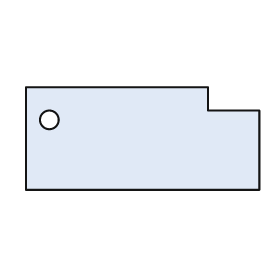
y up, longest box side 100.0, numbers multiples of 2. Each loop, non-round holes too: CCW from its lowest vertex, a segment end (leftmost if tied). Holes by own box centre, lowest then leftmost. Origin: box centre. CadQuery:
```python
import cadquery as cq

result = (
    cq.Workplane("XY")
    .moveTo(-50.0, -22.0)
    .lineTo(50.0, -22.0)
    .lineTo(50.0, 12.0)
    .lineTo(28.0, 12.0)
    .lineTo(28.0, 22.0)
    .lineTo(-50.0, 22.0)
    .close()
    .moveTo(-40.0, 8.0)
    .circle(4.0)
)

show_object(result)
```